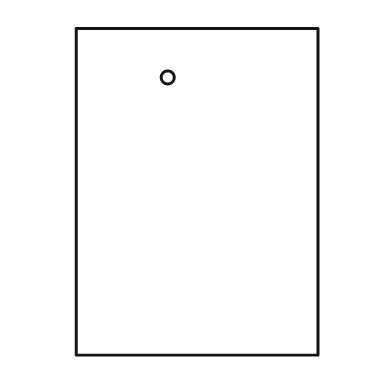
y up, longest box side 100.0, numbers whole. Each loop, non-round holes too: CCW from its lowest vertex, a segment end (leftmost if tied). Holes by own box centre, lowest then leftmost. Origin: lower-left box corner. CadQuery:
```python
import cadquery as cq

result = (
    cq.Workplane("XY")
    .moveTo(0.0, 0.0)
    .lineTo(74.0, 0.0)
    .lineTo(74.0, 100.0)
    .lineTo(0.0, 100.0)
    .close()
    .moveTo(28.0, 85.0)
    .circle(2.0)
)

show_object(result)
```